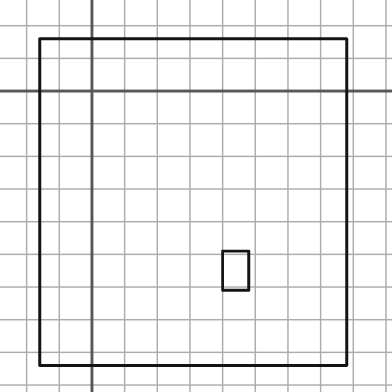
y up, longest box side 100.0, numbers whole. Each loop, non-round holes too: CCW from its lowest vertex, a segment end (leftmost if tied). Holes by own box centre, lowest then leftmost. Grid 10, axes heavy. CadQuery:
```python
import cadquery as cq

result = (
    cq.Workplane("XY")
    .moveTo(-16.0, -84.0)
    .lineTo(78.0, -84.0)
    .lineTo(78.0, 16.0)
    .lineTo(-16.0, 16.0)
    .close()
    .moveTo(40.0, -61.0)
    .lineTo(48.0, -61.0)
    .lineTo(48.0, -49.0)
    .lineTo(40.0, -49.0)
    .close()
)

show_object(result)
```